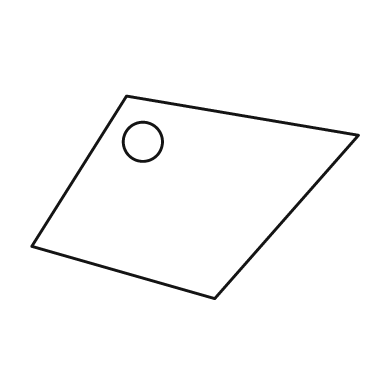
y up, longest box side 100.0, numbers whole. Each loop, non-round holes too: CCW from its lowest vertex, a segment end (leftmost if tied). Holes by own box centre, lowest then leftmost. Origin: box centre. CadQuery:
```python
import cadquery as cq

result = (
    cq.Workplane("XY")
    .moveTo(6.0, -31.0)
    .lineTo(50.0, 19.0)
    .lineTo(-21.0, 31.0)
    .lineTo(-50.0, -15.0)
    .close()
    .moveTo(-16.0, 17.0)
    .circle(6.0)
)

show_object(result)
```